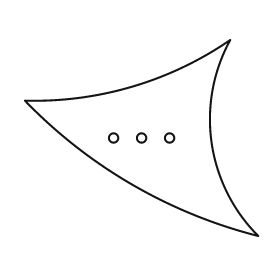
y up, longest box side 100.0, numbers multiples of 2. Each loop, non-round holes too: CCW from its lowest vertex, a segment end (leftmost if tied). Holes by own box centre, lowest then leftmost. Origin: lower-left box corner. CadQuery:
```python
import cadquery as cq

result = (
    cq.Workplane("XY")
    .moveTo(100.0, 0.0)
    .threePointArc((80.0, 40.0), (88.0, 84.0))
    .threePointArc((46.0, 64.0), (0.0, 58.0))
    .threePointArc((46.0, 22.0), (100.0, 0.0))
    .close()
    .moveTo(38.0, 42.0)
    .circle(2.0)
    .moveTo(50.0, 42.0)
    .circle(2.0)
    .moveTo(62.0, 42.0)
    .circle(2.0)
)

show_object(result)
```